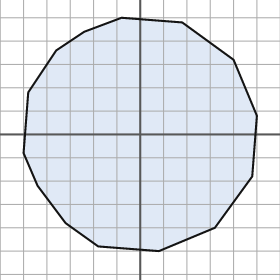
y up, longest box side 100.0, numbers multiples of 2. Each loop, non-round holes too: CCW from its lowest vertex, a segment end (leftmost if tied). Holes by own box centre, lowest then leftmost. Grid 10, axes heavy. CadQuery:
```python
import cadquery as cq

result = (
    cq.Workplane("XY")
    .moveTo(8.0, -50.0)
    .lineTo(32.0, -40.0)
    .lineTo(48.0, -18.0)
    .lineTo(50.0, 8.0)
    .lineTo(40.0, 32.0)
    .lineTo(18.0, 48.0)
    .lineTo(-8.0, 50.0)
    .lineTo(-24.0, 44.0)
    .lineTo(-36.0, 36.0)
    .lineTo(-48.0, 18.0)
    .lineTo(-50.0, -8.0)
    .lineTo(-44.0, -22.0)
    .lineTo(-32.0, -38.0)
    .lineTo(-18.0, -48.0)
    .close()
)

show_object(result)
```